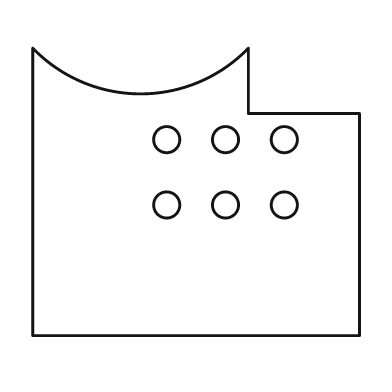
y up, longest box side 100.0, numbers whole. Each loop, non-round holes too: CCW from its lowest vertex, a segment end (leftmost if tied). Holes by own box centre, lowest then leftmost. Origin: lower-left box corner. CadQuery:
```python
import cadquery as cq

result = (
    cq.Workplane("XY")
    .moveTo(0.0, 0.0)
    .lineTo(100.0, 0.0)
    .lineTo(100.0, 68.0)
    .lineTo(66.0, 68.0)
    .lineTo(66.0, 88.0)
    .threePointArc((33.0, 74.0), (0.0, 88.0))
    .close()
    .moveTo(41.0, 40.0)
    .circle(4.0)
    .moveTo(59.0, 40.0)
    .circle(4.0)
    .moveTo(77.0, 40.0)
    .circle(4.0)
    .moveTo(41.0, 60.0)
    .circle(4.0)
    .moveTo(59.0, 60.0)
    .circle(4.0)
    .moveTo(77.0, 60.0)
    .circle(4.0)
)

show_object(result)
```